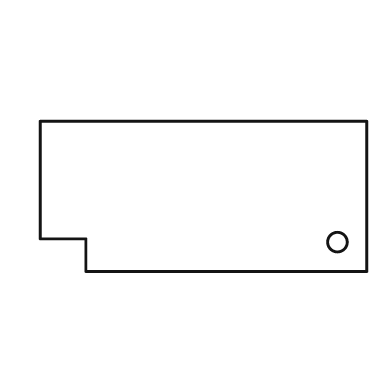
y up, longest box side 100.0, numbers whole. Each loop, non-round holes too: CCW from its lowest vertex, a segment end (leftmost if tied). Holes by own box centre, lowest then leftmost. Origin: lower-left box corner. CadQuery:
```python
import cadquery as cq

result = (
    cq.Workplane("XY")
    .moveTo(14.0, 0.0)
    .lineTo(100.0, 0.0)
    .lineTo(100.0, 46.0)
    .lineTo(0.0, 46.0)
    .lineTo(0.0, 10.0)
    .lineTo(14.0, 10.0)
    .close()
    .moveTo(91.0, 9.0)
    .circle(3.0)
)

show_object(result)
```